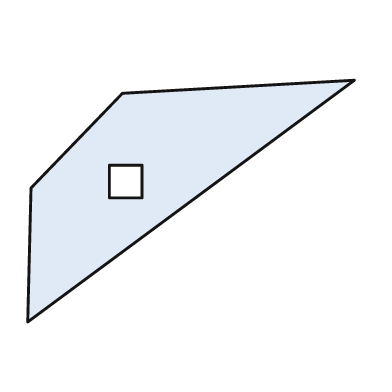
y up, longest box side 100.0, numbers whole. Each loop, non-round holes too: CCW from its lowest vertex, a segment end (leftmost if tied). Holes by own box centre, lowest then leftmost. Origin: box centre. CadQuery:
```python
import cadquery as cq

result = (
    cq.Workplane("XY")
    .moveTo(-50.0, -37.0)
    .lineTo(50.0, 37.0)
    .lineTo(-21.0, 33.0)
    .lineTo(-49.0, 4.0)
    .close()
    .moveTo(-25.0, 1.0)
    .lineTo(-15.0, 1.0)
    .lineTo(-15.0, 11.0)
    .lineTo(-25.0, 11.0)
    .close()
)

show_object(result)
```